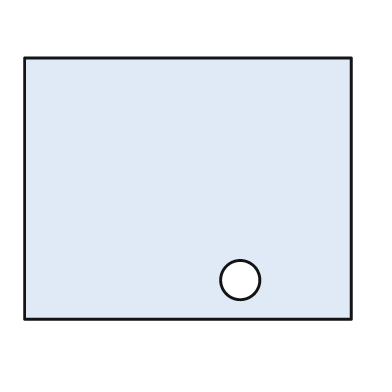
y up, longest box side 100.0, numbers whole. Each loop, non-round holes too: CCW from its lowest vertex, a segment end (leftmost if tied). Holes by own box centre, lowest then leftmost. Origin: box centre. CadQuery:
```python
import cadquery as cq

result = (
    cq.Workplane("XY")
    .moveTo(-50.0, -40.0)
    .lineTo(50.0, -40.0)
    .lineTo(50.0, 40.0)
    .lineTo(-50.0, 40.0)
    .close()
    .moveTo(16.0, -28.0)
    .circle(6.0)
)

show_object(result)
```